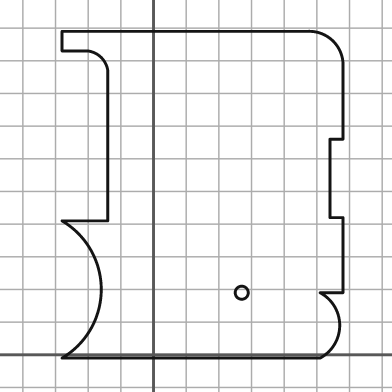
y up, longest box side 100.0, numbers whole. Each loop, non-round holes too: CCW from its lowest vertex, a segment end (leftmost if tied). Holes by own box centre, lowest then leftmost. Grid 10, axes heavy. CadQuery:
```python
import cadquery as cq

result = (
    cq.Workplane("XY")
    .moveTo(-28.0, -1.0)
    .lineTo(51.0, -1.0)
    .threePointArc((57.0, 9.0), (51.0, 19.0))
    .lineTo(58.0, 19.0)
    .lineTo(58.0, 42.0)
    .lineTo(54.0, 42.0)
    .lineTo(54.0, 66.0)
    .lineTo(58.0, 66.0)
    .lineTo(58.0, 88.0)
    .threePointArc((55.0, 96.0), (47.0, 99.0))
    .lineTo(-28.0, 99.0)
    .lineTo(-28.0, 93.0)
    .lineTo(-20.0, 93.0)
    .threePointArc((-16.0, 91.0), (-14.0, 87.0))
    .lineTo(-14.0, 41.0)
    .lineTo(-28.0, 41.0)
    .threePointArc((-16.0, 20.0), (-28.0, -1.0))
    .close()
    .moveTo(27.0, 19.0)
    .circle(2.0)
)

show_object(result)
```